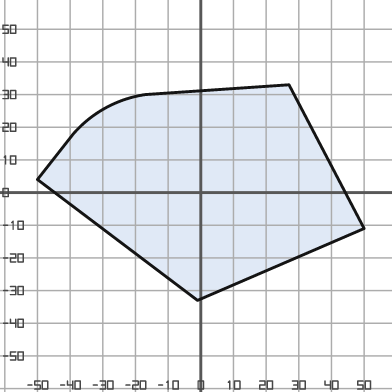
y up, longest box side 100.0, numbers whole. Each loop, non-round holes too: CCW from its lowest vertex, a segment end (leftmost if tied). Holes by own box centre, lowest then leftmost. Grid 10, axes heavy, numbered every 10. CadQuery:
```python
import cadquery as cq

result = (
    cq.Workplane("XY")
    .moveTo(-1.0, -33.0)
    .lineTo(50.0, -11.0)
    .lineTo(27.0, 33.0)
    .lineTo(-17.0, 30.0)
    .threePointArc((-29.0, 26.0), (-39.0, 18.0))
    .lineTo(-50.0, 4.0)
    .close()
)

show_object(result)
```